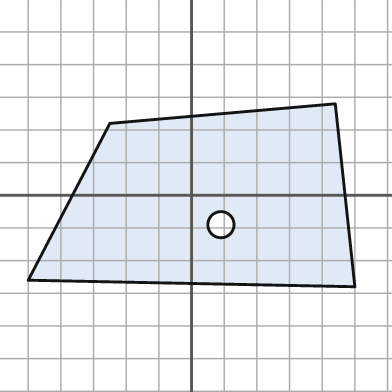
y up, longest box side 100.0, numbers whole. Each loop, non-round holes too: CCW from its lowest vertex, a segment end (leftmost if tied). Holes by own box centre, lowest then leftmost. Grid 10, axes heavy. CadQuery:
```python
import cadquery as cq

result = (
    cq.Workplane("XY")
    .moveTo(50.0, -28.0)
    .lineTo(44.0, 28.0)
    .lineTo(-25.0, 22.0)
    .lineTo(-50.0, -26.0)
    .close()
    .moveTo(9.0, -9.0)
    .circle(4.0)
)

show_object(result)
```